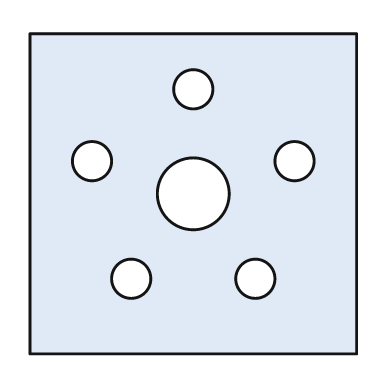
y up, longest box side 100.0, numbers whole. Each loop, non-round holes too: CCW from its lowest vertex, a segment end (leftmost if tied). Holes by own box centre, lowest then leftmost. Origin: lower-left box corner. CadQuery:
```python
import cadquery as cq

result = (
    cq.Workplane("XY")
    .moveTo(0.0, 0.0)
    .lineTo(100.0, 0.0)
    .lineTo(100.0, 98.0)
    .lineTo(0.0, 98.0)
    .close()
    .moveTo(31.0, 23.0)
    .circle(6.0)
    .moveTo(69.0, 23.0)
    .circle(6.0)
    .moveTo(50.0, 49.0)
    .circle(11.0)
    .moveTo(19.0, 59.0)
    .circle(6.0)
    .moveTo(81.0, 59.0)
    .circle(6.0)
    .moveTo(50.0, 81.0)
    .circle(6.0)
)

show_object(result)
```